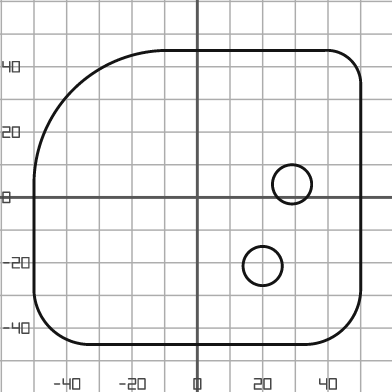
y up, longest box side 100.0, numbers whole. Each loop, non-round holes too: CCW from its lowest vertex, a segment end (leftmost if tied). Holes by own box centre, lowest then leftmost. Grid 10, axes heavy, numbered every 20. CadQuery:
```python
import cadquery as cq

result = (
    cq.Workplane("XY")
    .moveTo(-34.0, -45.0)
    .lineTo(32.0, -45.0)
    .threePointArc((45.0, -40.0), (50.0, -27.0))
    .lineTo(50.0, 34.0)
    .threePointArc((47.0, 42.0), (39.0, 45.0))
    .lineTo(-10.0, 45.0)
    .threePointArc((-38.0, 33.0), (-50.0, 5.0))
    .lineTo(-50.0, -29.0)
    .threePointArc((-45.0, -40.0), (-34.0, -45.0))
    .close()
    .moveTo(20.0, -21.0)
    .circle(6.0)
    .moveTo(29.0, 4.0)
    .circle(6.0)
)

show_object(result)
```